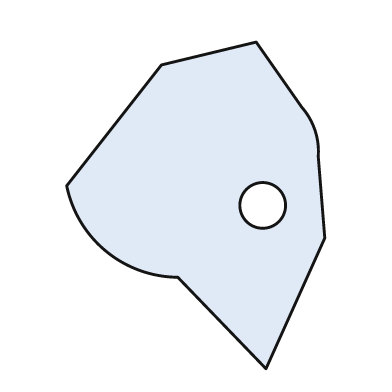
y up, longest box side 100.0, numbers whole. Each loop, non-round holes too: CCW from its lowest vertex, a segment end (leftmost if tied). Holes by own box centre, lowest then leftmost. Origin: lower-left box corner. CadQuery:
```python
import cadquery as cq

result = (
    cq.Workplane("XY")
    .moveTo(61.0, 0.0)
    .lineTo(79.0, 40.0)
    .lineTo(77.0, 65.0)
    .threePointArc((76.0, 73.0), (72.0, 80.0))
    .lineTo(58.0, 100.0)
    .lineTo(29.0, 93.0)
    .lineTo(0.0, 56.0)
    .threePointArc((12.0, 36.0), (34.0, 28.0))
    .close()
    .moveTo(60.0, 50.0)
    .circle(7.0)
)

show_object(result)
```